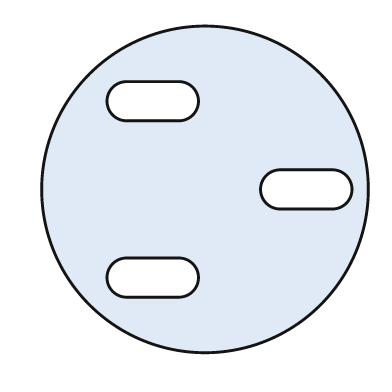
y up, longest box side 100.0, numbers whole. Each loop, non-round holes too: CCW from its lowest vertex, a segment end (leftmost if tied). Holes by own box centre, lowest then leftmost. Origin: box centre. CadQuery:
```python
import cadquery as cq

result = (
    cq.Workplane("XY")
    .moveTo(0.0, 0.0)
    .circle(50.0)
    .moveTo(-24.0, -33.0)
    .lineTo(-8.0, -33.0)
    .threePointArc((-2.0, -27.0), (-8.0, -21.0))
    .lineTo(-24.0, -21.0)
    .threePointArc((-30.0, -27.0), (-24.0, -33.0))
    .close()
    .moveTo(23.0, -6.0)
    .lineTo(39.0, -6.0)
    .threePointArc((45.0, 0.0), (39.0, 6.0))
    .lineTo(23.0, 6.0)
    .threePointArc((17.0, 0.0), (23.0, -6.0))
    .close()
    .moveTo(-24.0, 21.0)
    .lineTo(-8.0, 21.0)
    .threePointArc((-2.0, 27.0), (-8.0, 33.0))
    .lineTo(-24.0, 33.0)
    .threePointArc((-30.0, 27.0), (-24.0, 21.0))
    .close()
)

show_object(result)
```